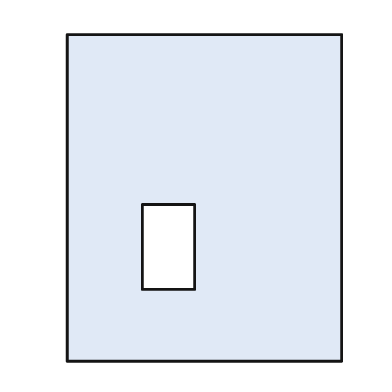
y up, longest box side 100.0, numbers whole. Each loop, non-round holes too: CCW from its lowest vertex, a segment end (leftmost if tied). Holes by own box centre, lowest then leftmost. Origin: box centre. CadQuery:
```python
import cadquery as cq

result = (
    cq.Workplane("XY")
    .moveTo(-42.0, -50.0)
    .lineTo(42.0, -50.0)
    .lineTo(42.0, 50.0)
    .lineTo(-42.0, 50.0)
    .close()
    .moveTo(-19.0, -28.0)
    .lineTo(-3.0, -28.0)
    .lineTo(-3.0, -2.0)
    .lineTo(-19.0, -2.0)
    .close()
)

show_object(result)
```